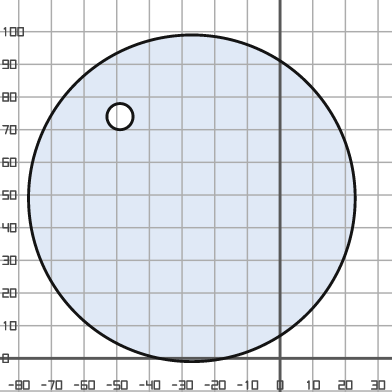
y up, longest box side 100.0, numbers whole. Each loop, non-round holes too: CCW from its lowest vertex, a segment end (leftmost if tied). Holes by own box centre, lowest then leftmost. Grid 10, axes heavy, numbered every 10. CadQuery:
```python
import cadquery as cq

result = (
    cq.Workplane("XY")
    .moveTo(-27.0, 49.0)
    .circle(50.0)
    .moveTo(-49.0, 74.0)
    .circle(4.0)
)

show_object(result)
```